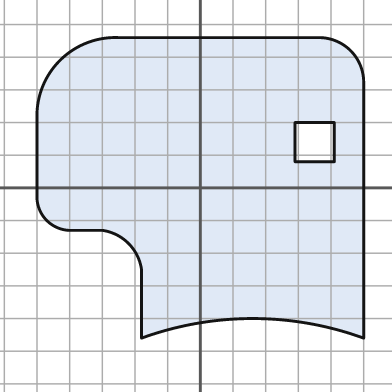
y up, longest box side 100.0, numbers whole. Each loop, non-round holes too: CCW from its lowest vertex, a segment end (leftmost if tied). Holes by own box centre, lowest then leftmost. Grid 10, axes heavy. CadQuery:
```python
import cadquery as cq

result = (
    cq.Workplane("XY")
    .moveTo(-18.0, -46.0)
    .threePointArc((16.0, -40.0), (50.0, -46.0))
    .lineTo(50.0, 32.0)
    .threePointArc((46.0, 42.0), (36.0, 46.0))
    .lineTo(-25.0, 46.0)
    .threePointArc((-43.0, 39.0), (-50.0, 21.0))
    .lineTo(-50.0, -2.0)
    .threePointArc((-47.0, -10.0), (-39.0, -13.0))
    .lineTo(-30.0, -13.0)
    .threePointArc((-22.0, -17.0), (-18.0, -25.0))
    .close()
    .moveTo(29.0, 8.0)
    .lineTo(41.0, 8.0)
    .lineTo(41.0, 20.0)
    .lineTo(29.0, 20.0)
    .close()
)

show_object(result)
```